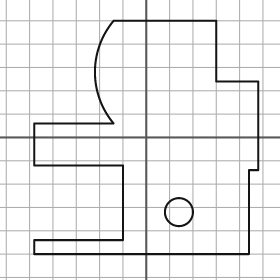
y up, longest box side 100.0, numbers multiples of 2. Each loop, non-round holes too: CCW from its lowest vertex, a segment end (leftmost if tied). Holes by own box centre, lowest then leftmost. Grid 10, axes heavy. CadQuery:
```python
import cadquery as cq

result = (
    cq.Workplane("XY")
    .moveTo(-48.0, -50.0)
    .lineTo(44.0, -50.0)
    .lineTo(44.0, -14.0)
    .lineTo(48.0, -14.0)
    .lineTo(48.0, 24.0)
    .lineTo(30.0, 24.0)
    .lineTo(30.0, 50.0)
    .lineTo(-14.0, 50.0)
    .threePointArc((-22.0, 28.0), (-14.0, 6.0))
    .lineTo(-48.0, 6.0)
    .lineTo(-48.0, -12.0)
    .lineTo(-10.0, -12.0)
    .lineTo(-10.0, -44.0)
    .lineTo(-48.0, -44.0)
    .close()
    .moveTo(14.0, -32.0)
    .circle(6.0)
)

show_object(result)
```